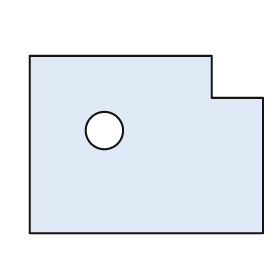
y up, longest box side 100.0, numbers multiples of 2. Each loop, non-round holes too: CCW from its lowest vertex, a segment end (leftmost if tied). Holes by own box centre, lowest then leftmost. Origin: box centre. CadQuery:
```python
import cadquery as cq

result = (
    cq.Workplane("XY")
    .moveTo(-50.0, -38.0)
    .lineTo(50.0, -38.0)
    .lineTo(50.0, 20.0)
    .lineTo(28.0, 20.0)
    .lineTo(28.0, 38.0)
    .lineTo(-50.0, 38.0)
    .close()
    .moveTo(-18.0, 6.0)
    .circle(8.0)
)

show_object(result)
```